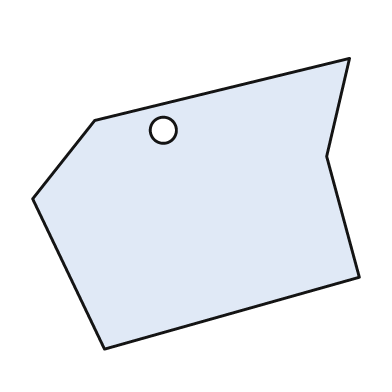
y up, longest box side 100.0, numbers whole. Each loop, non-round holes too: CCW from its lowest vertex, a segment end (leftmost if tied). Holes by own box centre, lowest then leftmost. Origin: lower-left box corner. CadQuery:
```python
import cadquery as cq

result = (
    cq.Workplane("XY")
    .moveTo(22.0, 0.0)
    .lineTo(100.0, 22.0)
    .lineTo(90.0, 59.0)
    .lineTo(97.0, 89.0)
    .lineTo(19.0, 70.0)
    .lineTo(0.0, 46.0)
    .close()
    .moveTo(40.0, 67.0)
    .circle(4.0)
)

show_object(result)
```